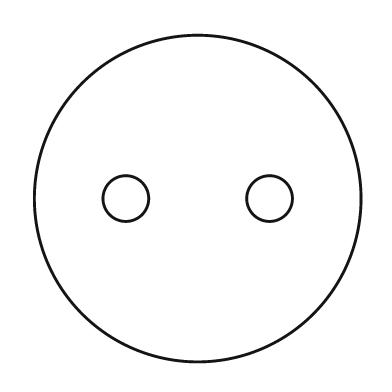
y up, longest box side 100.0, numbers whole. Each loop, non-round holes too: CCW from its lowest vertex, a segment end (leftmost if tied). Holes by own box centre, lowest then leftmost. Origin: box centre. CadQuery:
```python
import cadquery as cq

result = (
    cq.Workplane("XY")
    .moveTo(0.0, 0.0)
    .circle(50.0)
    .moveTo(-22.0, 0.0)
    .circle(7.0)
    .moveTo(22.0, 0.0)
    .circle(7.0)
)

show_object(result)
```